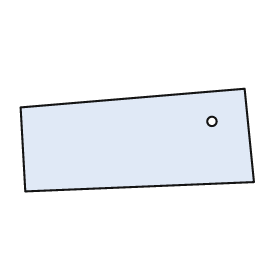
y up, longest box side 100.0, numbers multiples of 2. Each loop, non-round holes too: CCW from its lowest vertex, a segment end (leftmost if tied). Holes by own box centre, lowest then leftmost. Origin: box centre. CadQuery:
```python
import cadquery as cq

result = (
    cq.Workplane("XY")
    .moveTo(-48.0, -22.0)
    .lineTo(50.0, -18.0)
    .lineTo(46.0, 22.0)
    .lineTo(-50.0, 14.0)
    .close()
    .moveTo(32.0, 8.0)
    .circle(2.0)
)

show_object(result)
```